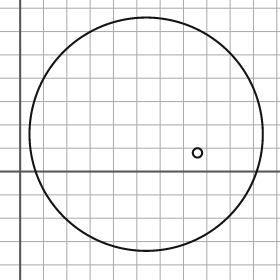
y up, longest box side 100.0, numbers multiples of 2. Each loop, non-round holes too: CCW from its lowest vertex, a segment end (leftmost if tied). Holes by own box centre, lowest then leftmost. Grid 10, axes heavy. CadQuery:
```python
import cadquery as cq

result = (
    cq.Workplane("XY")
    .moveTo(54.0, 16.0)
    .circle(50.0)
    .moveTo(76.0, 8.0)
    .circle(2.0)
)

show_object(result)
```